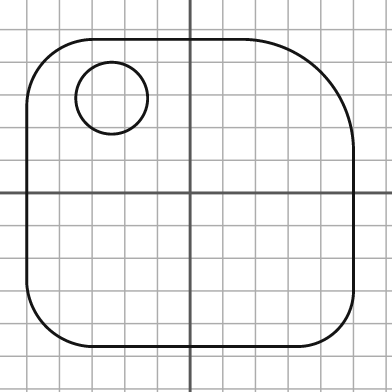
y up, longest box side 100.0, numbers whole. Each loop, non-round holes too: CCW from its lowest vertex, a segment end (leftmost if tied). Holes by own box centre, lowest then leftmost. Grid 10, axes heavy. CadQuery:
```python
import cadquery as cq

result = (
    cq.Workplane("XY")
    .moveTo(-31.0, -47.0)
    .lineTo(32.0, -47.0)
    .threePointArc((45.0, -42.0), (50.0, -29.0))
    .lineTo(50.0, 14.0)
    .threePointArc((40.0, 37.0), (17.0, 47.0))
    .lineTo(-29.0, 47.0)
    .threePointArc((-44.0, 41.0), (-50.0, 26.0))
    .lineTo(-50.0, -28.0)
    .threePointArc((-44.0, -41.0), (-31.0, -47.0))
    .close()
    .moveTo(-24.0, 29.0)
    .circle(11.0)
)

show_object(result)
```